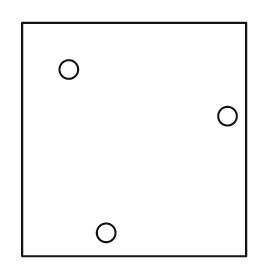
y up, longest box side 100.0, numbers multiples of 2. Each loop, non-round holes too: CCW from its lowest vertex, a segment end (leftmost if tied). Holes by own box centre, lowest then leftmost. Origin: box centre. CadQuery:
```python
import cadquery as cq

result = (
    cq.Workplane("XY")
    .moveTo(-48.0, -50.0)
    .lineTo(48.0, -50.0)
    .lineTo(48.0, 50.0)
    .lineTo(-48.0, 50.0)
    .close()
    .moveTo(-12.0, -40.0)
    .circle(4.0)
    .moveTo(40.0, 10.0)
    .circle(4.0)
    .moveTo(-28.0, 30.0)
    .circle(4.0)
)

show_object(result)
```